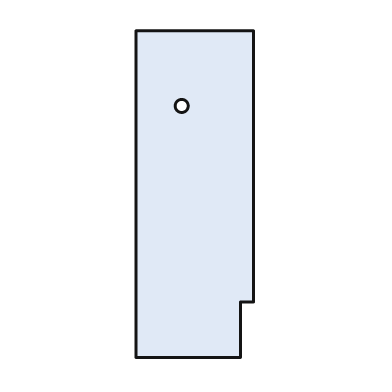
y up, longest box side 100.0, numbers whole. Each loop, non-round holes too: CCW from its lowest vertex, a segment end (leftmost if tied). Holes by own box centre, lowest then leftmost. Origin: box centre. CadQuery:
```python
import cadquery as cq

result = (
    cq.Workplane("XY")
    .moveTo(-18.0, -50.0)
    .lineTo(14.0, -50.0)
    .lineTo(14.0, -33.0)
    .lineTo(18.0, -33.0)
    .lineTo(18.0, 50.0)
    .lineTo(-18.0, 50.0)
    .close()
    .moveTo(-4.0, 27.0)
    .circle(2.0)
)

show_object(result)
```